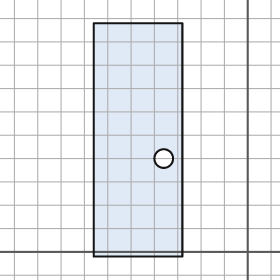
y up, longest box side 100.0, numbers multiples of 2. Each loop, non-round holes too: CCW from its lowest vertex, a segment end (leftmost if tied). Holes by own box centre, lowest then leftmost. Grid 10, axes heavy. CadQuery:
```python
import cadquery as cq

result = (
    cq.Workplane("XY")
    .moveTo(-66.0, -2.0)
    .lineTo(-28.0, -2.0)
    .lineTo(-28.0, 98.0)
    .lineTo(-66.0, 98.0)
    .close()
    .moveTo(-36.0, 40.0)
    .circle(4.0)
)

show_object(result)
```